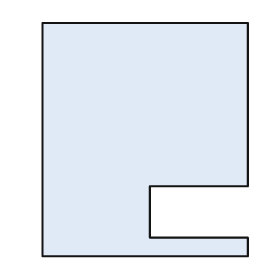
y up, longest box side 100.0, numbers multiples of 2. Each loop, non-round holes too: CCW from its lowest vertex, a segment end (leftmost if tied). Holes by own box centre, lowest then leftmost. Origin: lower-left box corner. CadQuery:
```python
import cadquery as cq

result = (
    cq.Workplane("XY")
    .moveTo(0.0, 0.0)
    .lineTo(88.0, 0.0)
    .lineTo(88.0, 8.0)
    .lineTo(46.0, 8.0)
    .lineTo(46.0, 30.0)
    .lineTo(88.0, 30.0)
    .lineTo(88.0, 100.0)
    .lineTo(0.0, 100.0)
    .close()
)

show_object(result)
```